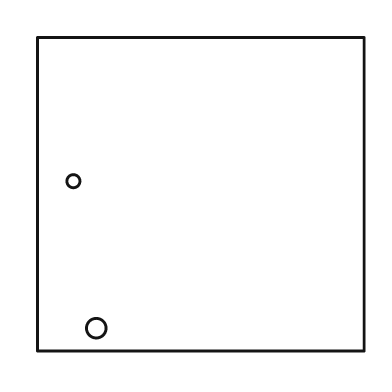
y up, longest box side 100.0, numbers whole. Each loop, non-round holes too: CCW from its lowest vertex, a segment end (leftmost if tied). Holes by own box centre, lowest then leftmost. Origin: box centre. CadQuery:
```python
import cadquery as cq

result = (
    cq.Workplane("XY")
    .moveTo(-50.0, -48.0)
    .lineTo(50.0, -48.0)
    .lineTo(50.0, 48.0)
    .lineTo(-50.0, 48.0)
    .close()
    .moveTo(-32.0, -41.0)
    .circle(3.0)
    .moveTo(-39.0, 4.0)
    .circle(2.0)
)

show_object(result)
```